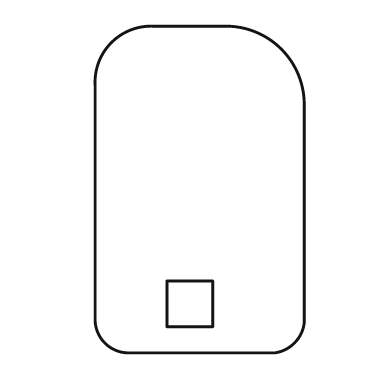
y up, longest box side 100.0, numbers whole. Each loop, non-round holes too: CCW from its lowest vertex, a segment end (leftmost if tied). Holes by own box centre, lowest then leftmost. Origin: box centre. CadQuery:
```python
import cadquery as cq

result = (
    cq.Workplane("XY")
    .moveTo(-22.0, -50.0)
    .lineTo(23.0, -50.0)
    .threePointArc((29.0, -47.0), (32.0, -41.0))
    .lineTo(32.0, 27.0)
    .threePointArc((25.0, 43.0), (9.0, 50.0))
    .lineTo(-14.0, 50.0)
    .threePointArc((-27.0, 45.0), (-32.0, 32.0))
    .lineTo(-32.0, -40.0)
    .threePointArc((-29.0, -47.0), (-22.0, -50.0))
    .close()
    .moveTo(-10.0, -42.0)
    .lineTo(4.0, -42.0)
    .lineTo(4.0, -28.0)
    .lineTo(-10.0, -28.0)
    .close()
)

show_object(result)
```